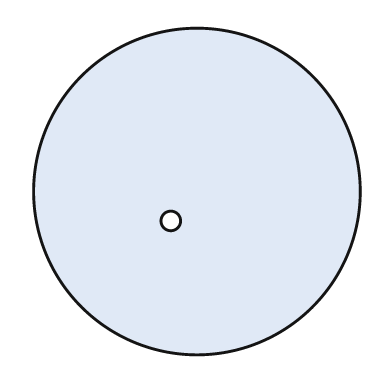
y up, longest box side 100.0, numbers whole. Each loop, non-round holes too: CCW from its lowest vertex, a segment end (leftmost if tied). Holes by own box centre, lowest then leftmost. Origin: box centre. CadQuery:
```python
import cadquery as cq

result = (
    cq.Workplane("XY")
    .moveTo(0.0, 0.0)
    .circle(50.0)
    .moveTo(-8.0, -9.0)
    .circle(3.0)
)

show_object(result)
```